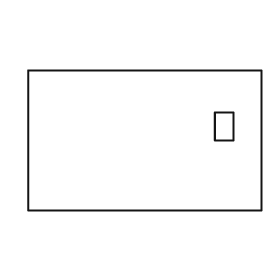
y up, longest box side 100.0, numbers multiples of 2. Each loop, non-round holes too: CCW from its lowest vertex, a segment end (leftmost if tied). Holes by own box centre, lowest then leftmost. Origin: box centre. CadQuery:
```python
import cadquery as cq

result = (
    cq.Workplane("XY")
    .moveTo(-50.0, -30.0)
    .lineTo(50.0, -30.0)
    .lineTo(50.0, 30.0)
    .lineTo(-50.0, 30.0)
    .close()
    .moveTo(30.0, 0.0)
    .lineTo(38.0, 0.0)
    .lineTo(38.0, 12.0)
    .lineTo(30.0, 12.0)
    .close()
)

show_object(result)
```